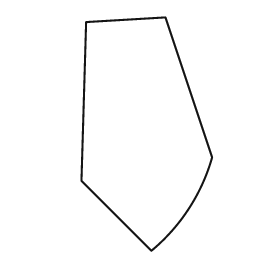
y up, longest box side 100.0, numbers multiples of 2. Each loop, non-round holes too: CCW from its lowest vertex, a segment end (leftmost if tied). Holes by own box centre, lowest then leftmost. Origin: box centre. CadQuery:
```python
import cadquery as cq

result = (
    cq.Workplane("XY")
    .moveTo(2.0, -50.0)
    .threePointArc((18.0, -32.0), (28.0, -10.0))
    .lineTo(8.0, 50.0)
    .lineTo(-26.0, 48.0)
    .lineTo(-28.0, -20.0)
    .close()
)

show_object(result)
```